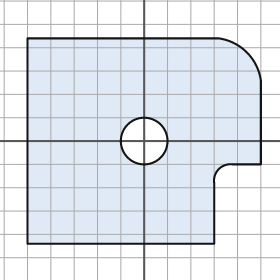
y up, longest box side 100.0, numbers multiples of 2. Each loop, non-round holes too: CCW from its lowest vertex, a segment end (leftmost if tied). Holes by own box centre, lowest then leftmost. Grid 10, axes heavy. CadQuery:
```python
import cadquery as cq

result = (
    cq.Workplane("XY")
    .moveTo(-50.0, -44.0)
    .lineTo(30.0, -44.0)
    .lineTo(30.0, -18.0)
    .threePointArc((32.0, -12.0), (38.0, -10.0))
    .lineTo(50.0, -10.0)
    .lineTo(50.0, 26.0)
    .threePointArc((44.0, 38.0), (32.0, 44.0))
    .lineTo(-50.0, 44.0)
    .close()
    .moveTo(0.0, 0.0)
    .circle(10.0)
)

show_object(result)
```